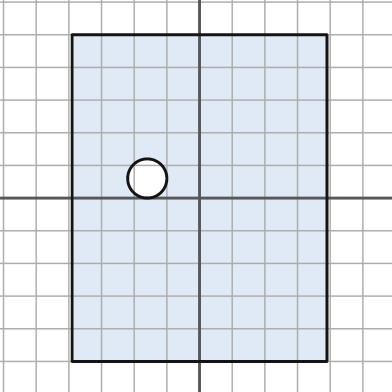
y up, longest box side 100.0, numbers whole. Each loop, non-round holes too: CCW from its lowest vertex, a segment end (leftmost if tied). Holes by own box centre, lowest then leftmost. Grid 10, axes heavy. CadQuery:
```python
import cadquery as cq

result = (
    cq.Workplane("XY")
    .moveTo(-39.0, -50.0)
    .lineTo(39.0, -50.0)
    .lineTo(39.0, 50.0)
    .lineTo(-39.0, 50.0)
    .close()
    .moveTo(-16.0, 6.0)
    .circle(6.0)
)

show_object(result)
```